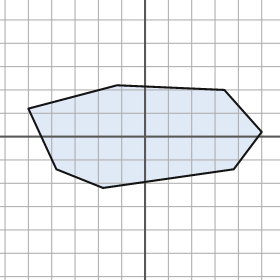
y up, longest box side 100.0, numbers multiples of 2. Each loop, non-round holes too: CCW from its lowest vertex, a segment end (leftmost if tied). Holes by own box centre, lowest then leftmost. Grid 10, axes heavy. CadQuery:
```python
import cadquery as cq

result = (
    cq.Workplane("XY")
    .moveTo(-18.0, -22.0)
    .lineTo(38.0, -14.0)
    .lineTo(50.0, 2.0)
    .lineTo(34.0, 20.0)
    .lineTo(-12.0, 22.0)
    .lineTo(-50.0, 12.0)
    .lineTo(-38.0, -14.0)
    .close()
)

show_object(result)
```